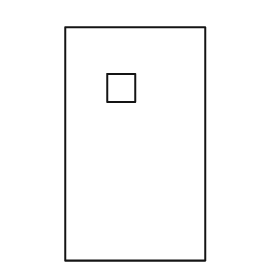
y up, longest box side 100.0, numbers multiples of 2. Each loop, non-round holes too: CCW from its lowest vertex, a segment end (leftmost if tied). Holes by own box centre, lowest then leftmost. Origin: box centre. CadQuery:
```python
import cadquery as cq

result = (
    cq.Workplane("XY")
    .moveTo(-30.0, -50.0)
    .lineTo(30.0, -50.0)
    .lineTo(30.0, 50.0)
    .lineTo(-30.0, 50.0)
    .close()
    .moveTo(-12.0, 18.0)
    .lineTo(0.0, 18.0)
    .lineTo(0.0, 30.0)
    .lineTo(-12.0, 30.0)
    .close()
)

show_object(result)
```